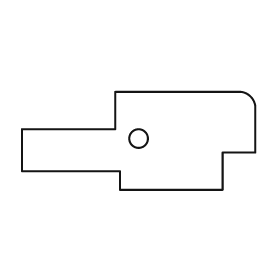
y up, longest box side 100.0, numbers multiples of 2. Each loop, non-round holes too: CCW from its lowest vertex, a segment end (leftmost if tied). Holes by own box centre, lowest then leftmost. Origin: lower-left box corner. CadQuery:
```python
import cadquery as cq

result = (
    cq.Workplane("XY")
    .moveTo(42.0, 0.0)
    .lineTo(86.0, 0.0)
    .lineTo(86.0, 16.0)
    .lineTo(100.0, 16.0)
    .lineTo(100.0, 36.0)
    .threePointArc((98.0, 40.0), (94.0, 42.0))
    .lineTo(40.0, 42.0)
    .lineTo(40.0, 26.0)
    .lineTo(0.0, 26.0)
    .lineTo(0.0, 8.0)
    .lineTo(42.0, 8.0)
    .close()
    .moveTo(50.0, 22.0)
    .circle(4.0)
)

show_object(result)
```